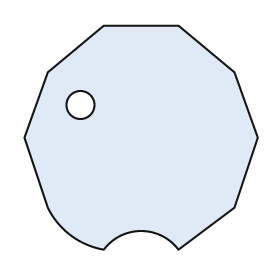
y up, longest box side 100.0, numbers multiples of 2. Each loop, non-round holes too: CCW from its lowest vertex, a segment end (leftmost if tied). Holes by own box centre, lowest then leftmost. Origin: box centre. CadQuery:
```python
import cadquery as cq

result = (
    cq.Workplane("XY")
    .moveTo(-16.0, -48.0)
    .threePointArc((0.0, -40.0), (16.0, -48.0))
    .lineTo(40.0, -30.0)
    .lineTo(50.0, 0.0)
    .lineTo(40.0, 28.0)
    .lineTo(16.0, 48.0)
    .lineTo(-16.0, 48.0)
    .lineTo(-40.0, 28.0)
    .lineTo(-50.0, 0.0)
    .lineTo(-40.0, -30.0)
    .threePointArc((-30.0, -42.0), (-16.0, -48.0))
    .close()
    .moveTo(-26.0, 14.0)
    .circle(6.0)
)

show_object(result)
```